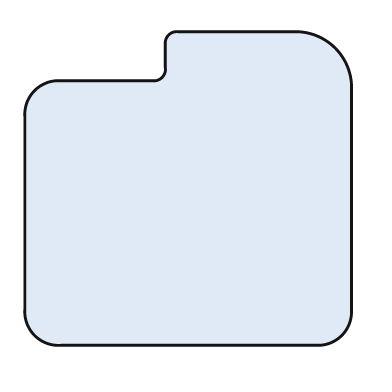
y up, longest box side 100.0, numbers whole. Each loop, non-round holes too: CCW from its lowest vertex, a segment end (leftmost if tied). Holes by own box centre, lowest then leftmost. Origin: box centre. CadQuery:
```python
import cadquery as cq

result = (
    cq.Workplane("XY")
    .moveTo(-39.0, -48.0)
    .lineTo(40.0, -48.0)
    .threePointArc((47.0, -45.0), (50.0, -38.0))
    .lineTo(50.0, 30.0)
    .threePointArc((45.0, 43.0), (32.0, 48.0))
    .lineTo(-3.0, 48.0)
    .threePointArc((-6.0, 47.0), (-7.0, 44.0))
    .lineTo(-7.0, 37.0)
    .threePointArc((-8.0, 34.0), (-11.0, 33.0))
    .lineTo(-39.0, 33.0)
    .threePointArc((-47.0, 30.0), (-50.0, 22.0))
    .lineTo(-50.0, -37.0)
    .threePointArc((-47.0, -45.0), (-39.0, -48.0))
    .close()
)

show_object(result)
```